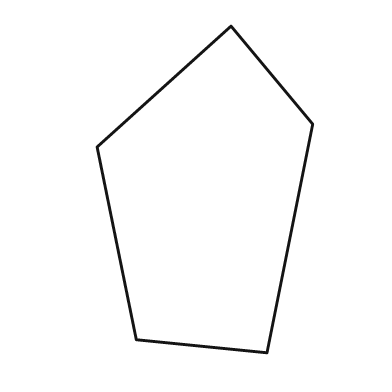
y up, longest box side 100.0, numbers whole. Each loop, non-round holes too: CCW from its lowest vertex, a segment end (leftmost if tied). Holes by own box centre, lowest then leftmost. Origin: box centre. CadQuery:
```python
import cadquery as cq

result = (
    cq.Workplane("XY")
    .moveTo(19.0, -50.0)
    .lineTo(33.0, 20.0)
    .lineTo(8.0, 50.0)
    .lineTo(-33.0, 13.0)
    .lineTo(-21.0, -46.0)
    .close()
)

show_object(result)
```